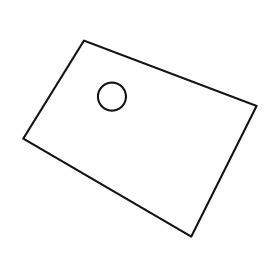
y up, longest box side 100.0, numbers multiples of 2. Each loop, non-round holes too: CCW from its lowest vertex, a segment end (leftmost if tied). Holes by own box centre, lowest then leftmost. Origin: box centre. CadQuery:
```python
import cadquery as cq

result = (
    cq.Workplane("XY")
    .moveTo(22.0, -42.0)
    .lineTo(50.0, 14.0)
    .lineTo(-24.0, 42.0)
    .lineTo(-50.0, 0.0)
    .close()
    .moveTo(-12.0, 18.0)
    .circle(6.0)
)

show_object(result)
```